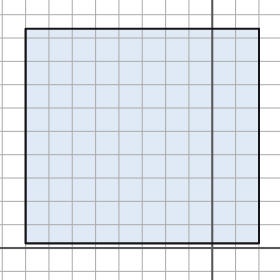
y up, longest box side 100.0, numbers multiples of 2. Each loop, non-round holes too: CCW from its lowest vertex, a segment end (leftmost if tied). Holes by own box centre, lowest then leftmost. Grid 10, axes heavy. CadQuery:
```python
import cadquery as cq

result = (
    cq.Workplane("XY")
    .moveTo(-80.0, 2.0)
    .lineTo(20.0, 2.0)
    .lineTo(20.0, 94.0)
    .lineTo(-80.0, 94.0)
    .close()
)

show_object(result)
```